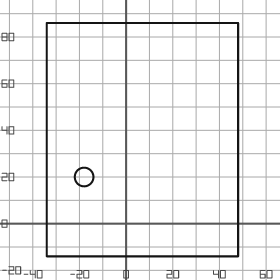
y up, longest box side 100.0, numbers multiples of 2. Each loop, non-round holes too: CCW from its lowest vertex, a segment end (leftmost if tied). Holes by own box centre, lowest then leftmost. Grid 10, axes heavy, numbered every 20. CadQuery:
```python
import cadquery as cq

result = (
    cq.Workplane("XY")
    .moveTo(-34.0, -14.0)
    .lineTo(48.0, -14.0)
    .lineTo(48.0, 86.0)
    .lineTo(-34.0, 86.0)
    .close()
    .moveTo(-18.0, 20.0)
    .circle(4.0)
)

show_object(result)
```